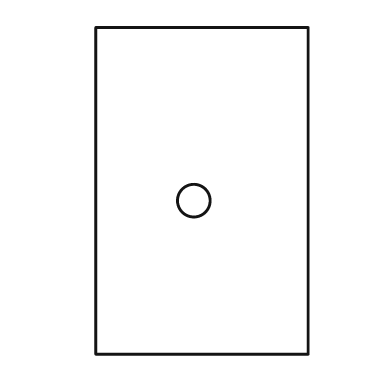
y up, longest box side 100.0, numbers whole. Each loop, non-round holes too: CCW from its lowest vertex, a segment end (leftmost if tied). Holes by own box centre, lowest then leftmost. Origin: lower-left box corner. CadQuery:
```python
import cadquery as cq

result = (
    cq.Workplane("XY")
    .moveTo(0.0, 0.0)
    .lineTo(65.0, 0.0)
    .lineTo(65.0, 100.0)
    .lineTo(0.0, 100.0)
    .close()
    .moveTo(30.0, 47.0)
    .circle(5.0)
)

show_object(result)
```